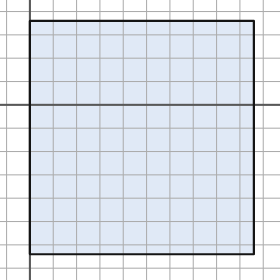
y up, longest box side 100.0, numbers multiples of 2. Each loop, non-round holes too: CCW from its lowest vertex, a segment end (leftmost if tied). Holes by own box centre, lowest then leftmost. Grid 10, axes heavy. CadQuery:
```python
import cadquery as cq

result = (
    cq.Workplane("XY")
    .moveTo(0.0, -64.0)
    .lineTo(96.0, -64.0)
    .lineTo(96.0, 36.0)
    .lineTo(0.0, 36.0)
    .close()
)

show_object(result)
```